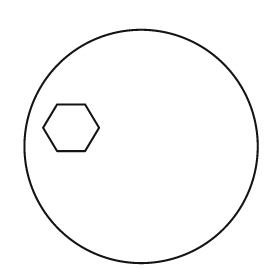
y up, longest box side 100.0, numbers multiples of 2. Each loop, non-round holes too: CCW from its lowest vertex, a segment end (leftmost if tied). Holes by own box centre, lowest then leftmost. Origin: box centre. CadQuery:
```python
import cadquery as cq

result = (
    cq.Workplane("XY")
    .moveTo(0.0, 0.0)
    .circle(50.0)
    .moveTo(-36.0, -2.0)
    .lineTo(-24.0, -2.0)
    .lineTo(-18.0, 8.0)
    .lineTo(-24.0, 18.0)
    .lineTo(-36.0, 18.0)
    .lineTo(-42.0, 8.0)
    .close()
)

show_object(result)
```